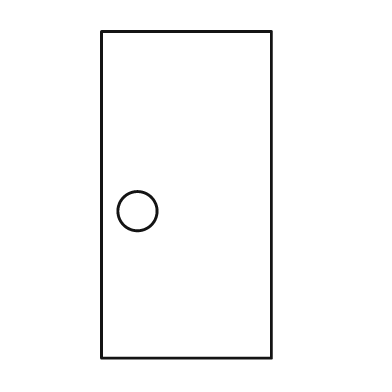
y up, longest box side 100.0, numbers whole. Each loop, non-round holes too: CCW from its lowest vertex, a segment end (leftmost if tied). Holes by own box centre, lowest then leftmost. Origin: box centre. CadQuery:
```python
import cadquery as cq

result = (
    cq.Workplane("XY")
    .moveTo(-26.0, -50.0)
    .lineTo(26.0, -50.0)
    .lineTo(26.0, 50.0)
    .lineTo(-26.0, 50.0)
    .close()
    .moveTo(-15.0, -5.0)
    .circle(6.0)
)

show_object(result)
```